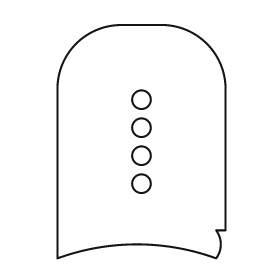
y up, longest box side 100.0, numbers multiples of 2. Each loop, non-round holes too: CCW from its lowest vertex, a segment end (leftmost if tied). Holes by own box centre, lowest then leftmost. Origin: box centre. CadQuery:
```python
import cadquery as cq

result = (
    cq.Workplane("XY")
    .moveTo(-36.0, -50.0)
    .threePointArc((-2.0, -44.0), (32.0, -50.0))
    .threePointArc((34.0, -44.0), (32.0, -38.0))
    .lineTo(36.0, -38.0)
    .lineTo(36.0, 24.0)
    .threePointArc((28.0, 42.0), (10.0, 50.0))
    .lineTo(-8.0, 50.0)
    .threePointArc((-28.0, 42.0), (-36.0, 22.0))
    .close()
    .moveTo(0.0, -18.0)
    .circle(4.0)
    .moveTo(0.0, -6.0)
    .circle(4.0)
    .moveTo(0.0, 6.0)
    .circle(4.0)
    .moveTo(0.0, 18.0)
    .circle(4.0)
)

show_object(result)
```